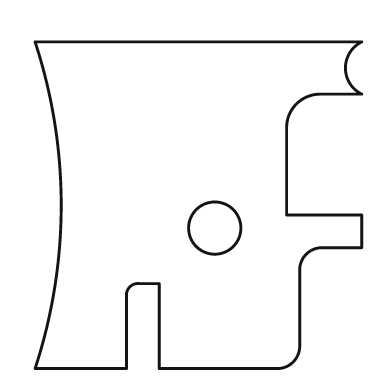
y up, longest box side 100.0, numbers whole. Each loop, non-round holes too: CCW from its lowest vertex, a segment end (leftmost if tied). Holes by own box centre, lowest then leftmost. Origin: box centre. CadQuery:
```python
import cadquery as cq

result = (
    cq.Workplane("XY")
    .moveTo(-50.0, -50.0)
    .lineTo(-22.0, -50.0)
    .lineTo(-22.0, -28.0)
    .threePointArc((-21.0, -25.0), (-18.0, -24.0))
    .lineTo(-12.0, -24.0)
    .lineTo(-12.0, -50.0)
    .lineTo(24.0, -50.0)
    .threePointArc((29.0, -48.0), (31.0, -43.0))
    .lineTo(31.0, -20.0)
    .threePointArc((33.0, -15.0), (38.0, -13.0))
    .lineTo(50.0, -13.0)
    .lineTo(50.0, -3.0)
    .lineTo(27.0, -3.0)
    .lineTo(27.0, 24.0)
    .threePointArc((30.0, 31.0), (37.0, 34.0))
    .lineTo(50.0, 34.0)
    .threePointArc((45.0, 42.0), (50.0, 50.0))
    .lineTo(-50.0, 50.0)
    .threePointArc((-42.0, 0.0), (-50.0, -50.0))
    .close()
    .moveTo(5.0, -7.0)
    .circle(8.0)
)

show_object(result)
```